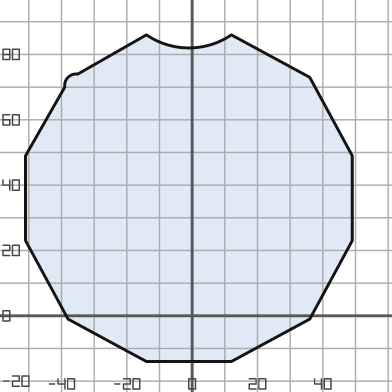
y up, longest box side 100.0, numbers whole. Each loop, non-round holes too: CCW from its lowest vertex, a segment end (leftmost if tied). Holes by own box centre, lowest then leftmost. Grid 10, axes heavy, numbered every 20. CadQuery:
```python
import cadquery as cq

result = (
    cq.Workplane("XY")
    .moveTo(-14.0, -14.0)
    .lineTo(12.0, -14.0)
    .lineTo(36.0, -1.0)
    .lineTo(49.0, 23.0)
    .lineTo(49.0, 49.0)
    .lineTo(36.0, 73.0)
    .lineTo(12.0, 86.0)
    .threePointArc((-1.0, 82.0), (-14.0, 86.0))
    .lineTo(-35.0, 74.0)
    .threePointArc((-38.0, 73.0), (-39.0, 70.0))
    .lineTo(-51.0, 49.0)
    .lineTo(-51.0, 23.0)
    .lineTo(-38.0, -1.0)
    .close()
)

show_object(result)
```